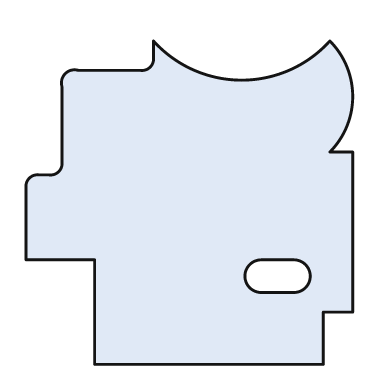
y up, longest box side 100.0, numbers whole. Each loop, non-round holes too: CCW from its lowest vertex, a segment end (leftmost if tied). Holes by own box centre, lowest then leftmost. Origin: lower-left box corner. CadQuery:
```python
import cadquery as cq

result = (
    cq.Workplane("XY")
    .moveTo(21.0, 0.0)
    .lineTo(91.0, 0.0)
    .lineTo(91.0, 16.0)
    .lineTo(100.0, 16.0)
    .lineTo(100.0, 65.0)
    .lineTo(93.0, 65.0)
    .threePointArc((100.0, 82.0), (93.0, 99.0))
    .threePointArc((66.0, 87.0), (39.0, 99.0))
    .lineTo(39.0, 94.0)
    .threePointArc((38.0, 91.0), (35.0, 90.0))
    .lineTo(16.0, 90.0)
    .threePointArc((12.0, 89.0), (11.0, 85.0))
    .lineTo(11.0, 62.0)
    .threePointArc((10.0, 59.0), (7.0, 58.0))
    .lineTo(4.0, 58.0)
    .threePointArc((1.0, 57.0), (0.0, 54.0))
    .lineTo(0.0, 32.0)
    .lineTo(21.0, 32.0)
    .close()
    .moveTo(72.0, 22.0)
    .lineTo(82.0, 22.0)
    .threePointArc((87.0, 27.0), (82.0, 32.0))
    .lineTo(72.0, 32.0)
    .threePointArc((67.0, 27.0), (72.0, 22.0))
    .close()
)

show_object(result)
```